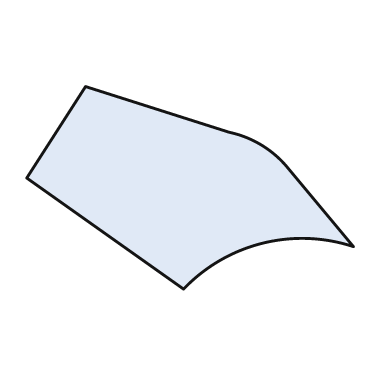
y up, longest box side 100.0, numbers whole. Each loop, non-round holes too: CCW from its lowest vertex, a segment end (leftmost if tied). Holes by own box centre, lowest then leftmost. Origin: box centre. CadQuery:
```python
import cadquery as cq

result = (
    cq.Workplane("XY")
    .moveTo(-2.0, -31.0)
    .threePointArc((22.0, -17.0), (50.0, -18.0))
    .lineTo(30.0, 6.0)
    .threePointArc((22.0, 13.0), (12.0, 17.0))
    .lineTo(-32.0, 31.0)
    .lineTo(-50.0, 3.0)
    .close()
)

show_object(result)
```